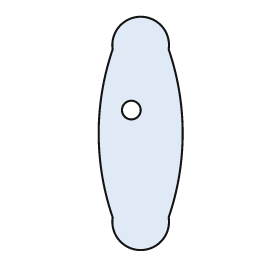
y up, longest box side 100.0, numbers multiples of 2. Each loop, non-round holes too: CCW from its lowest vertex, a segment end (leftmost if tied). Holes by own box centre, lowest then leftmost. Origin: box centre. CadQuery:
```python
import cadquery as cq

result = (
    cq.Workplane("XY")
    .moveTo(-12.0, -36.0)
    .threePointArc((0.0, -50.0), (12.0, -36.0))
    .threePointArc((18.0, 0.0), (12.0, 36.0))
    .threePointArc((0.0, 50.0), (-12.0, 36.0))
    .threePointArc((-18.0, 0.0), (-12.0, -36.0))
    .close()
    .moveTo(-4.0, 10.0)
    .circle(4.0)
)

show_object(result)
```